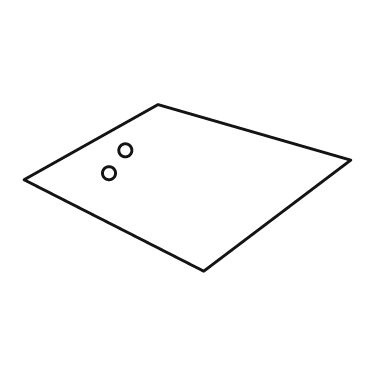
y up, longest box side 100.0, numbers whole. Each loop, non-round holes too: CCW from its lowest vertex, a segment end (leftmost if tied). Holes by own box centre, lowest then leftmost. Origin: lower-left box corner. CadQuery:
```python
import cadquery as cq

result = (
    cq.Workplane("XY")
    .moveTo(55.0, 0.0)
    .lineTo(100.0, 34.0)
    .lineTo(41.0, 51.0)
    .lineTo(0.0, 28.0)
    .close()
    .moveTo(26.0, 30.0)
    .circle(2.0)
    .moveTo(31.0, 37.0)
    .circle(2.0)
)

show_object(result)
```